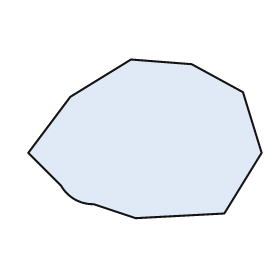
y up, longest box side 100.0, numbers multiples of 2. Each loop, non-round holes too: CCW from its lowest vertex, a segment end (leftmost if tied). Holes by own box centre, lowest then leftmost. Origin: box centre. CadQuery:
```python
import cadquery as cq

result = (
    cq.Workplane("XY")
    .moveTo(-4.0, -34.0)
    .lineTo(34.0, -32.0)
    .lineTo(50.0, -6.0)
    .lineTo(42.0, 20.0)
    .lineTo(20.0, 32.0)
    .lineTo(-6.0, 34.0)
    .lineTo(-32.0, 18.0)
    .lineTo(-50.0, -6.0)
    .lineTo(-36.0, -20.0)
    .threePointArc((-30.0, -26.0), (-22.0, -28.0))
    .close()
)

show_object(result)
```